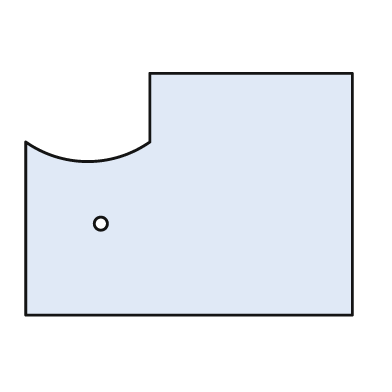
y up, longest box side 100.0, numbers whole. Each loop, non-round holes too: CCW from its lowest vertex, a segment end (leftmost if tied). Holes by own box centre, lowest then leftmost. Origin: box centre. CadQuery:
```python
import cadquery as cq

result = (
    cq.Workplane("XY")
    .moveTo(-50.0, -37.0)
    .lineTo(50.0, -37.0)
    .lineTo(50.0, 37.0)
    .lineTo(-12.0, 37.0)
    .lineTo(-12.0, 16.0)
    .threePointArc((-31.0, 10.0), (-50.0, 16.0))
    .close()
    .moveTo(-27.0, -9.0)
    .circle(2.0)
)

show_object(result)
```